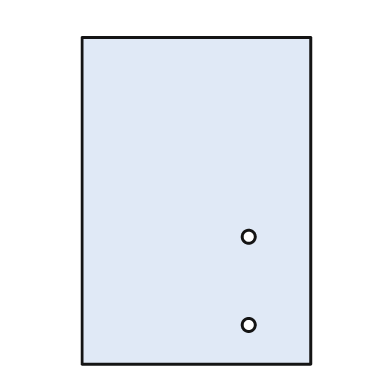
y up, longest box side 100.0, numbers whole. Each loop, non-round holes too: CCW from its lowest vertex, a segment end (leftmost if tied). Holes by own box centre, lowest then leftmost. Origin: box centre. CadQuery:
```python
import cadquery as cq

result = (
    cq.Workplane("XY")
    .moveTo(-35.0, -50.0)
    .lineTo(35.0, -50.0)
    .lineTo(35.0, 50.0)
    .lineTo(-35.0, 50.0)
    .close()
    .moveTo(16.0, -38.0)
    .circle(2.0)
    .moveTo(16.0, -11.0)
    .circle(2.0)
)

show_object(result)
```